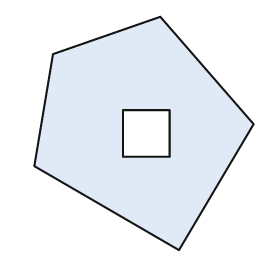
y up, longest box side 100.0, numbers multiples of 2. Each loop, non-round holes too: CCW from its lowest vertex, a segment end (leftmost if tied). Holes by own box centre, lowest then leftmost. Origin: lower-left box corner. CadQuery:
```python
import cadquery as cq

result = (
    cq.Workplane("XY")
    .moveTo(62.0, 0.0)
    .lineTo(94.0, 54.0)
    .lineTo(54.0, 100.0)
    .lineTo(8.0, 84.0)
    .lineTo(0.0, 36.0)
    .close()
    .moveTo(38.0, 40.0)
    .lineTo(58.0, 40.0)
    .lineTo(58.0, 60.0)
    .lineTo(38.0, 60.0)
    .close()
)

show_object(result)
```